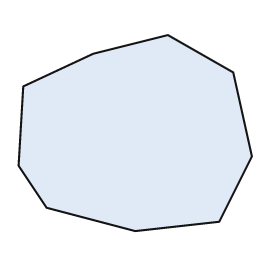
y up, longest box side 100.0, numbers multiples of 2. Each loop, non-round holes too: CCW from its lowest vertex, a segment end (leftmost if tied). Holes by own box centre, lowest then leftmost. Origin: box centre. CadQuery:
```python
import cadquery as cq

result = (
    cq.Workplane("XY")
    .moveTo(0.0, -42.0)
    .lineTo(36.0, -38.0)
    .lineTo(50.0, -10.0)
    .lineTo(42.0, 26.0)
    .lineTo(14.0, 42.0)
    .lineTo(-18.0, 34.0)
    .lineTo(-48.0, 20.0)
    .lineTo(-50.0, -14.0)
    .lineTo(-38.0, -32.0)
    .close()
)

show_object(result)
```